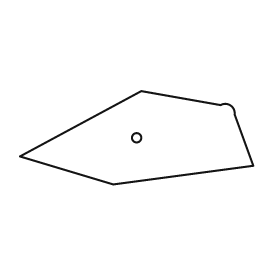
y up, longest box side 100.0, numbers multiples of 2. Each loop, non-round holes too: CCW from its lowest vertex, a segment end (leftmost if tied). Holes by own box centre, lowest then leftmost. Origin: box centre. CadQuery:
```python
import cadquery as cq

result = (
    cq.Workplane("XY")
    .moveTo(-10.0, -20.0)
    .lineTo(50.0, -12.0)
    .lineTo(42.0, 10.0)
    .threePointArc((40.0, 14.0), (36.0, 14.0))
    .lineTo(2.0, 20.0)
    .lineTo(-50.0, -8.0)
    .close()
    .moveTo(0.0, 0.0)
    .circle(2.0)
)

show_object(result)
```